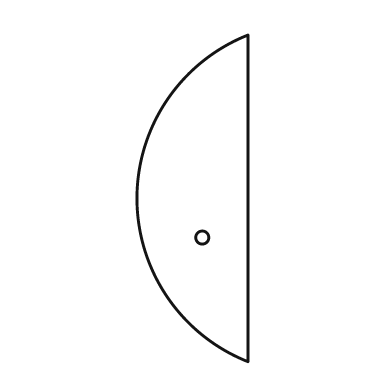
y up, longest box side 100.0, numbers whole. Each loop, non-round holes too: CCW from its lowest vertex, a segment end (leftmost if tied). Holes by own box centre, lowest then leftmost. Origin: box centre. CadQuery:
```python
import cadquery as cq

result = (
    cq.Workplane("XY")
    .moveTo(17.0, -50.0)
    .lineTo(17.0, 50.0)
    .threePointArc((-17.0, 0.0), (17.0, -50.0))
    .close()
    .moveTo(3.0, -12.0)
    .circle(2.0)
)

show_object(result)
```